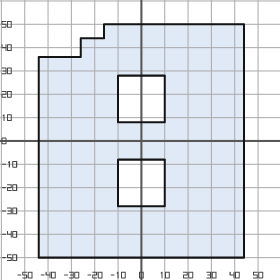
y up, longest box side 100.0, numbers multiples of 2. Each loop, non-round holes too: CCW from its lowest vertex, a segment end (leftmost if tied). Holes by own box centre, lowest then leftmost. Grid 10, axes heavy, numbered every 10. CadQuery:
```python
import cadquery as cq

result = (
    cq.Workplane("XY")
    .moveTo(-44.0, -50.0)
    .lineTo(44.0, -50.0)
    .lineTo(44.0, 50.0)
    .lineTo(-16.0, 50.0)
    .lineTo(-16.0, 44.0)
    .lineTo(-26.0, 44.0)
    .lineTo(-26.0, 36.0)
    .lineTo(-44.0, 36.0)
    .close()
    .moveTo(-10.0, -28.0)
    .lineTo(10.0, -28.0)
    .lineTo(10.0, -8.0)
    .lineTo(-10.0, -8.0)
    .close()
    .moveTo(-10.0, 8.0)
    .lineTo(10.0, 8.0)
    .lineTo(10.0, 28.0)
    .lineTo(-10.0, 28.0)
    .close()
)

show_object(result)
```